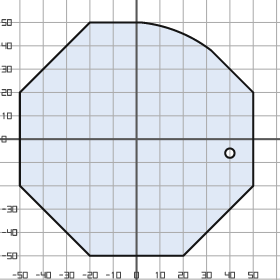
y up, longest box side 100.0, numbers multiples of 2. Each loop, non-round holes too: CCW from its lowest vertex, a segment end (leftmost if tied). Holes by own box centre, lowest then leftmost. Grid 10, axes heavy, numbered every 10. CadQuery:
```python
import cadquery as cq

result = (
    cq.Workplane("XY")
    .moveTo(-20.0, -50.0)
    .lineTo(20.0, -50.0)
    .lineTo(50.0, -20.0)
    .lineTo(50.0, 20.0)
    .lineTo(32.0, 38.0)
    .threePointArc((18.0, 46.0), (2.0, 50.0))
    .lineTo(-20.0, 50.0)
    .lineTo(-50.0, 20.0)
    .lineTo(-50.0, -20.0)
    .close()
    .moveTo(40.0, -6.0)
    .circle(2.0)
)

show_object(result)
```